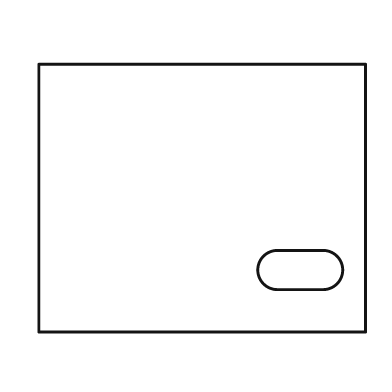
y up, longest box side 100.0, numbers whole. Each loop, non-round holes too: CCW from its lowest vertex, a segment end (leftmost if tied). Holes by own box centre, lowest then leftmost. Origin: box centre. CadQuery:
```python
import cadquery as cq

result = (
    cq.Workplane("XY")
    .moveTo(-50.0, -41.0)
    .lineTo(50.0, -41.0)
    .lineTo(50.0, 41.0)
    .lineTo(-50.0, 41.0)
    .close()
    .moveTo(23.0, -28.0)
    .lineTo(37.0, -28.0)
    .threePointArc((43.0, -22.0), (37.0, -16.0))
    .lineTo(23.0, -16.0)
    .threePointArc((17.0, -22.0), (23.0, -28.0))
    .close()
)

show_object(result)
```